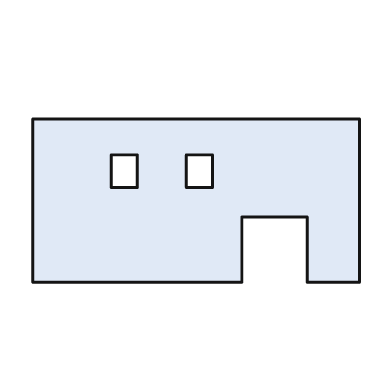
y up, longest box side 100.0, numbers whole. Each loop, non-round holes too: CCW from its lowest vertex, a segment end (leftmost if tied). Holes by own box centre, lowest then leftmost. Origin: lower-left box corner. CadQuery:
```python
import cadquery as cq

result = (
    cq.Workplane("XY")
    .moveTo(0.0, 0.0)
    .lineTo(64.0, 0.0)
    .lineTo(64.0, 20.0)
    .lineTo(84.0, 20.0)
    .lineTo(84.0, 0.0)
    .lineTo(100.0, 0.0)
    .lineTo(100.0, 50.0)
    .lineTo(0.0, 50.0)
    .close()
    .moveTo(24.0, 29.0)
    .lineTo(32.0, 29.0)
    .lineTo(32.0, 39.0)
    .lineTo(24.0, 39.0)
    .close()
    .moveTo(47.0, 29.0)
    .lineTo(55.0, 29.0)
    .lineTo(55.0, 39.0)
    .lineTo(47.0, 39.0)
    .close()
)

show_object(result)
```